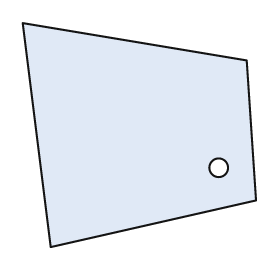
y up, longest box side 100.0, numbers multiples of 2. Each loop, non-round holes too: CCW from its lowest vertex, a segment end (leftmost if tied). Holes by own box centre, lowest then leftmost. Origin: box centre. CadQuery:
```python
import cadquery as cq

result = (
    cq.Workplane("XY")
    .moveTo(-38.0, -48.0)
    .lineTo(50.0, -28.0)
    .lineTo(46.0, 32.0)
    .lineTo(-50.0, 48.0)
    .close()
    .moveTo(34.0, -14.0)
    .circle(4.0)
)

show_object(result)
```